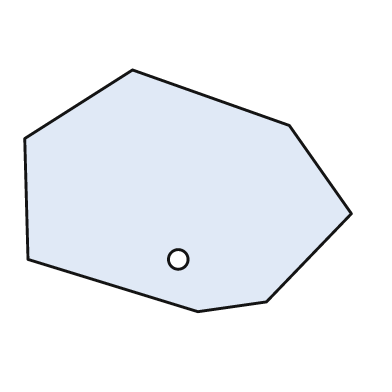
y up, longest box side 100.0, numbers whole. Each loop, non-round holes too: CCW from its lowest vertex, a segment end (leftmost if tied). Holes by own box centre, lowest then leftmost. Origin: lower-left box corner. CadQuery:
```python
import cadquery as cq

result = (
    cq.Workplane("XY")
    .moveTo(53.0, 0.0)
    .lineTo(74.0, 3.0)
    .lineTo(100.0, 30.0)
    .lineTo(81.0, 57.0)
    .lineTo(33.0, 74.0)
    .lineTo(0.0, 53.0)
    .lineTo(1.0, 16.0)
    .close()
    .moveTo(47.0, 16.0)
    .circle(3.0)
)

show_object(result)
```